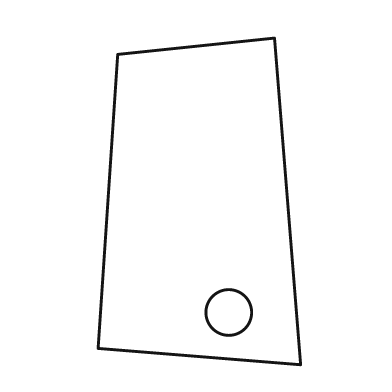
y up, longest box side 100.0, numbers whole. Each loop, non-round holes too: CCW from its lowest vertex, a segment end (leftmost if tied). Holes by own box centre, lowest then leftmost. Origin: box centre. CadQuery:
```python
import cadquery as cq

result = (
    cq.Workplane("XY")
    .moveTo(31.0, -50.0)
    .lineTo(23.0, 50.0)
    .lineTo(-25.0, 45.0)
    .lineTo(-31.0, -45.0)
    .close()
    .moveTo(9.0, -34.0)
    .circle(7.0)
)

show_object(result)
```